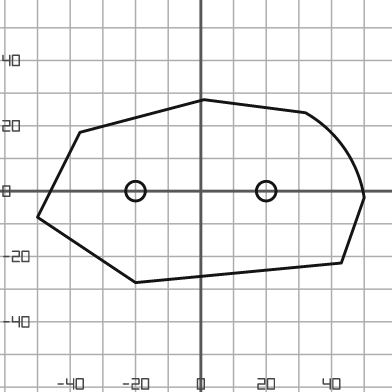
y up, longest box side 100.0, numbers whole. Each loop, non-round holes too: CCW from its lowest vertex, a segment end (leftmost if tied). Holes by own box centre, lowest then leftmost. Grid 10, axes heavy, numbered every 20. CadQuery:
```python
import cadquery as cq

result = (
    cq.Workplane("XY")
    .moveTo(-20.0, -28.0)
    .lineTo(43.0, -22.0)
    .lineTo(50.0, -2.0)
    .threePointArc((44.0, 13.0), (32.0, 24.0))
    .lineTo(1.0, 28.0)
    .lineTo(-37.0, 18.0)
    .lineTo(-50.0, -8.0)
    .close()
    .moveTo(-20.0, 0.0)
    .circle(3.0)
    .moveTo(20.0, 0.0)
    .circle(3.0)
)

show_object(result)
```